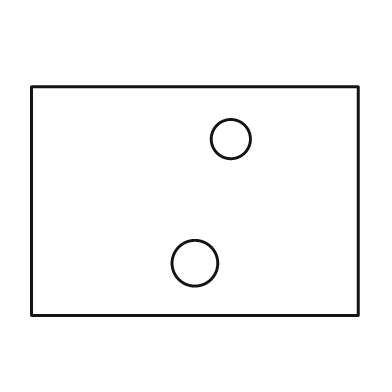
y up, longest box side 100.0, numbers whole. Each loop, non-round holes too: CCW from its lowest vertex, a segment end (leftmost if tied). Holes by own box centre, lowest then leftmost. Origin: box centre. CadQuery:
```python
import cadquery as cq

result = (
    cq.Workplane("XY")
    .moveTo(-50.0, -35.0)
    .lineTo(50.0, -35.0)
    .lineTo(50.0, 35.0)
    .lineTo(-50.0, 35.0)
    .close()
    .moveTo(0.0, -19.0)
    .circle(7.0)
    .moveTo(11.0, 19.0)
    .circle(6.0)
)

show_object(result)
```